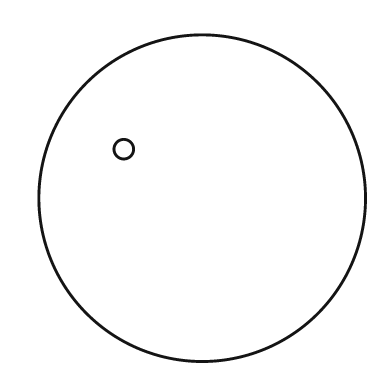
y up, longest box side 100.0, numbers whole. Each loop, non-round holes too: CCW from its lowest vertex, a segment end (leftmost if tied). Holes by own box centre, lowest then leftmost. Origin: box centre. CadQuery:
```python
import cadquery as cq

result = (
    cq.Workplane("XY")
    .moveTo(0.0, 0.0)
    .circle(50.0)
    .moveTo(-24.0, 15.0)
    .circle(3.0)
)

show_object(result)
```